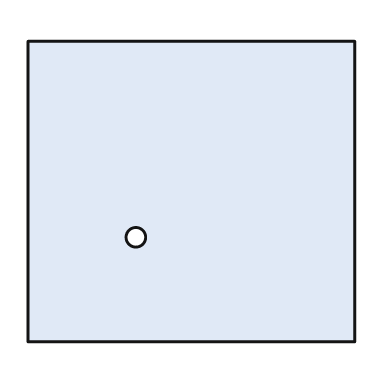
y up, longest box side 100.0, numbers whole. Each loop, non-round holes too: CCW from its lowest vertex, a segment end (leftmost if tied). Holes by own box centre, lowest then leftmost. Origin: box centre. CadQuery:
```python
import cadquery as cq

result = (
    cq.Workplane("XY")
    .moveTo(-50.0, -46.0)
    .lineTo(50.0, -46.0)
    .lineTo(50.0, 46.0)
    .lineTo(-50.0, 46.0)
    .close()
    .moveTo(-17.0, -14.0)
    .circle(3.0)
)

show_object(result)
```